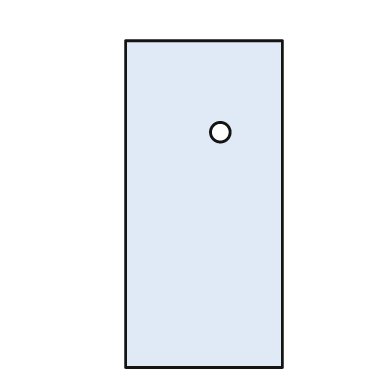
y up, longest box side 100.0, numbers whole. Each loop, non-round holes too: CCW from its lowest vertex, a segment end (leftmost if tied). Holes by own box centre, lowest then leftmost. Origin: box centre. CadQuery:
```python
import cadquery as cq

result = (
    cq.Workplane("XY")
    .moveTo(-24.0, -50.0)
    .lineTo(24.0, -50.0)
    .lineTo(24.0, 50.0)
    .lineTo(-24.0, 50.0)
    .close()
    .moveTo(5.0, 22.0)
    .circle(3.0)
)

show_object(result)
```